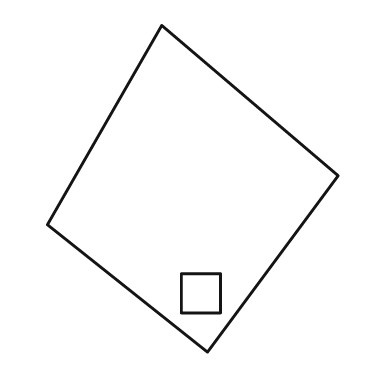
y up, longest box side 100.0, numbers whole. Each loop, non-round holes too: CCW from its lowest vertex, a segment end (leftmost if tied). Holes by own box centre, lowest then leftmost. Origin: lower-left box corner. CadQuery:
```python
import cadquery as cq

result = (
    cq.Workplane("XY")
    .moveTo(49.0, 0.0)
    .lineTo(89.0, 54.0)
    .lineTo(35.0, 100.0)
    .lineTo(0.0, 39.0)
    .close()
    .moveTo(41.0, 12.0)
    .lineTo(53.0, 12.0)
    .lineTo(53.0, 24.0)
    .lineTo(41.0, 24.0)
    .close()
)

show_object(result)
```